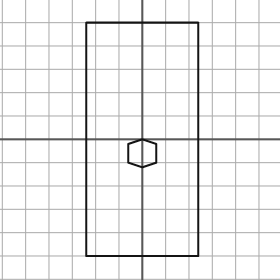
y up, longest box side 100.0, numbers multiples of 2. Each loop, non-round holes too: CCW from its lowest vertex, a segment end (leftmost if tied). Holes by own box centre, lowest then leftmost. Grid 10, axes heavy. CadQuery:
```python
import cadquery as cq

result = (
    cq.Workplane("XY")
    .moveTo(-24.0, -50.0)
    .lineTo(24.0, -50.0)
    .lineTo(24.0, 50.0)
    .lineTo(-24.0, 50.0)
    .close()
    .moveTo(0.0, -12.0)
    .lineTo(6.0, -10.0)
    .lineTo(6.0, -2.0)
    .lineTo(0.0, 0.0)
    .lineTo(-6.0, -2.0)
    .lineTo(-6.0, -10.0)
    .close()
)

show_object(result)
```